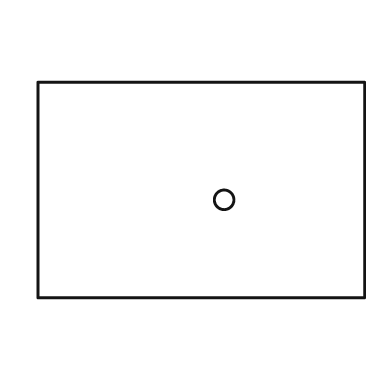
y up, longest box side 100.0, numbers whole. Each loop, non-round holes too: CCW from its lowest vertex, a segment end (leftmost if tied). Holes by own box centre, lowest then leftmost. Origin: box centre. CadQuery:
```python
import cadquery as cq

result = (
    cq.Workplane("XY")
    .moveTo(-50.0, -33.0)
    .lineTo(50.0, -33.0)
    .lineTo(50.0, 33.0)
    .lineTo(-50.0, 33.0)
    .close()
    .moveTo(7.0, -3.0)
    .circle(3.0)
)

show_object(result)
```